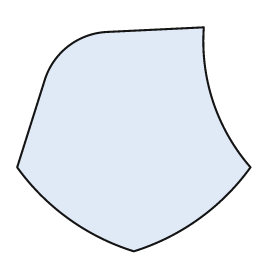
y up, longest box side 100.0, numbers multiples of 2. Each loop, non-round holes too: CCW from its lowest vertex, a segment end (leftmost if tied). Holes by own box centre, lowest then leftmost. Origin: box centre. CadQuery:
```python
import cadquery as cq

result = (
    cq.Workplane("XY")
    .moveTo(0.0, -48.0)
    .threePointArc((28.0, -34.0), (50.0, -12.0))
    .threePointArc((34.0, 16.0), (30.0, 48.0))
    .lineTo(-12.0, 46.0)
    .threePointArc((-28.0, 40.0), (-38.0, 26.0))
    .lineTo(-50.0, -12.0)
    .threePointArc((-28.0, -34.0), (0.0, -48.0))
    .close()
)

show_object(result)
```